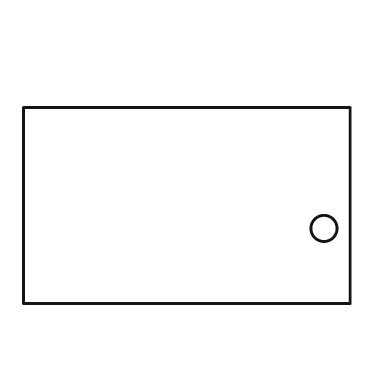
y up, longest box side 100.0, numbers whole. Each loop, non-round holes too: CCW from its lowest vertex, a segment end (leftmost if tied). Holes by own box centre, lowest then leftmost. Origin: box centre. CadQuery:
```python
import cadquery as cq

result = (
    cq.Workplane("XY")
    .moveTo(-50.0, -30.0)
    .lineTo(50.0, -30.0)
    .lineTo(50.0, 30.0)
    .lineTo(-50.0, 30.0)
    .close()
    .moveTo(42.0, -7.0)
    .circle(4.0)
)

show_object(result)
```